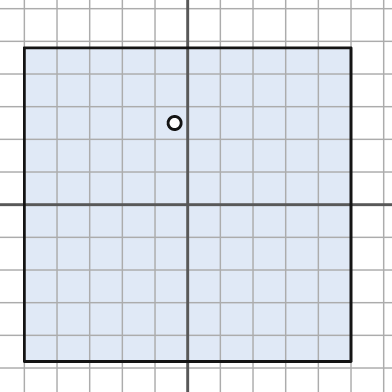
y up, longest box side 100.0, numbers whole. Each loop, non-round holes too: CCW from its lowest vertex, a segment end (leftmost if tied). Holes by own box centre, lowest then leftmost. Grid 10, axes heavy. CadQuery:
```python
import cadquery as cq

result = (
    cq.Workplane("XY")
    .moveTo(-50.0, -48.0)
    .lineTo(50.0, -48.0)
    .lineTo(50.0, 48.0)
    .lineTo(-50.0, 48.0)
    .close()
    .moveTo(-4.0, 25.0)
    .circle(2.0)
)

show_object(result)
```